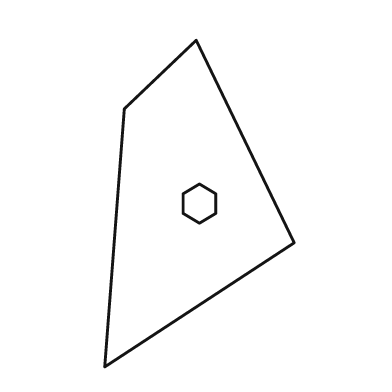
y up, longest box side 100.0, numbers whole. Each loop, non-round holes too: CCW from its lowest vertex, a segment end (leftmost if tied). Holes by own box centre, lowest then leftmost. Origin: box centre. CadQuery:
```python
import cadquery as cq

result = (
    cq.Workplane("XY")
    .moveTo(-29.0, -50.0)
    .lineTo(29.0, -12.0)
    .lineTo(-1.0, 50.0)
    .lineTo(-23.0, 29.0)
    .close()
    .moveTo(0.0, -6.0)
    .lineTo(5.0, -3.0)
    .lineTo(5.0, 3.0)
    .lineTo(0.0, 6.0)
    .lineTo(-5.0, 3.0)
    .lineTo(-5.0, -3.0)
    .close()
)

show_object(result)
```